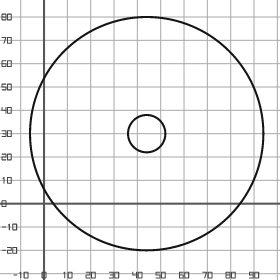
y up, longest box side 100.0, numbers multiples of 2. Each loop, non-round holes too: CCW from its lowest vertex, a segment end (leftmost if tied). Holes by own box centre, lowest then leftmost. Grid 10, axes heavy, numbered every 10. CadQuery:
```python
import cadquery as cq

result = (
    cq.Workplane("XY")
    .moveTo(44.0, 30.0)
    .circle(50.0)
    .moveTo(44.0, 30.0)
    .circle(8.0)
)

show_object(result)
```